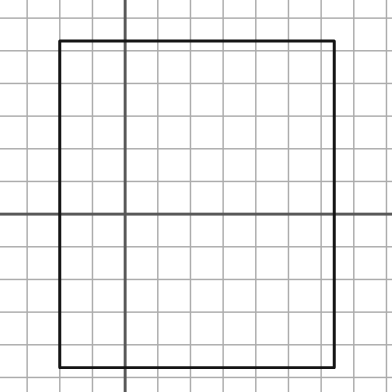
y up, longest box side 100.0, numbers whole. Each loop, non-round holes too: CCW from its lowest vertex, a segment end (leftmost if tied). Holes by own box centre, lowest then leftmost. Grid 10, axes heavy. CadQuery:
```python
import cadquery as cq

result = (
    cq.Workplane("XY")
    .moveTo(-20.0, -47.0)
    .lineTo(64.0, -47.0)
    .lineTo(64.0, 53.0)
    .lineTo(-20.0, 53.0)
    .close()
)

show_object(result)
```